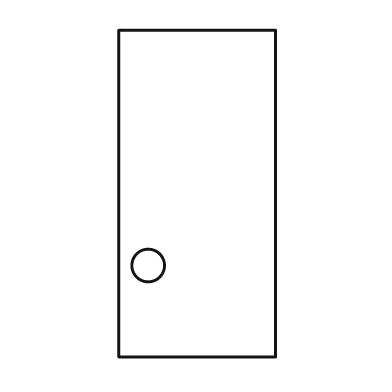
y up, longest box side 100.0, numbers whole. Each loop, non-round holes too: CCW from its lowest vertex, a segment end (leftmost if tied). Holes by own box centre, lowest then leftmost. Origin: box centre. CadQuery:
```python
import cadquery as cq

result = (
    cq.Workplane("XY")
    .moveTo(-24.0, -50.0)
    .lineTo(24.0, -50.0)
    .lineTo(24.0, 50.0)
    .lineTo(-24.0, 50.0)
    .close()
    .moveTo(-15.0, -22.0)
    .circle(5.0)
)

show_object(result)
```